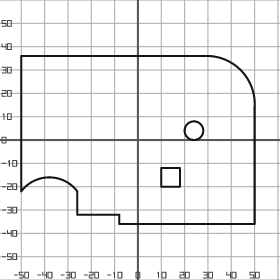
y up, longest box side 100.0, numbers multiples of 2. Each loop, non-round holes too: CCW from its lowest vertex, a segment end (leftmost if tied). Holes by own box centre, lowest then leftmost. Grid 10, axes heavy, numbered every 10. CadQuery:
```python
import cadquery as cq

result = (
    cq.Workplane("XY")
    .moveTo(-8.0, -36.0)
    .lineTo(50.0, -36.0)
    .lineTo(50.0, 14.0)
    .threePointArc((44.0, 30.0), (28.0, 36.0))
    .lineTo(-50.0, 36.0)
    .lineTo(-50.0, -22.0)
    .threePointArc((-38.0, -16.0), (-26.0, -22.0))
    .lineTo(-26.0, -32.0)
    .lineTo(-8.0, -32.0)
    .close()
    .moveTo(10.0, -20.0)
    .lineTo(18.0, -20.0)
    .lineTo(18.0, -12.0)
    .lineTo(10.0, -12.0)
    .close()
    .moveTo(24.0, 4.0)
    .circle(4.0)
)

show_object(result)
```